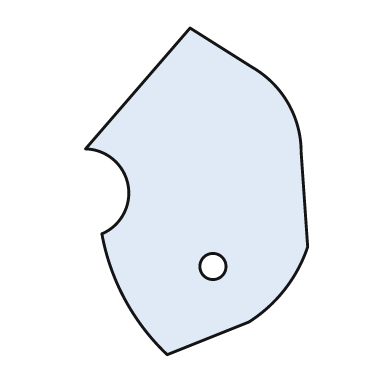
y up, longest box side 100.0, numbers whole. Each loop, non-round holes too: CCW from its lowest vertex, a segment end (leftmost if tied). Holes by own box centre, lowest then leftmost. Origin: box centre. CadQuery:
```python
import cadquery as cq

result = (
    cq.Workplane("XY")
    .moveTo(-9.0, -50.0)
    .lineTo(16.0, -40.0)
    .threePointArc((27.0, -30.0), (34.0, -17.0))
    .lineTo(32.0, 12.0)
    .threePointArc((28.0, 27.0), (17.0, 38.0))
    .lineTo(-2.0, 50.0)
    .lineTo(-34.0, 13.0)
    .threePointArc((-21.0, 2.0), (-29.0, -13.0))
    .threePointArc((-22.0, -33.0), (-9.0, -50.0))
    .close()
    .moveTo(5.0, -23.0)
    .circle(4.0)
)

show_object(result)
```